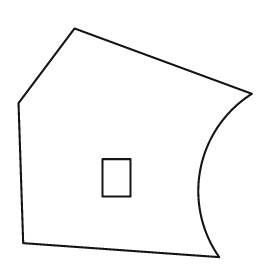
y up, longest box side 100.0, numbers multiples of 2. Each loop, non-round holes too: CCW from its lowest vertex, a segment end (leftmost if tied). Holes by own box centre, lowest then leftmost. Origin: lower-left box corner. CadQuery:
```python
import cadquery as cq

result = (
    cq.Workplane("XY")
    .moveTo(86.0, 0.0)
    .threePointArc((78.0, 38.0), (100.0, 70.0))
    .lineTo(24.0, 98.0)
    .lineTo(0.0, 66.0)
    .lineTo(2.0, 6.0)
    .close()
    .moveTo(36.0, 26.0)
    .lineTo(48.0, 26.0)
    .lineTo(48.0, 42.0)
    .lineTo(36.0, 42.0)
    .close()
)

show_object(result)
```